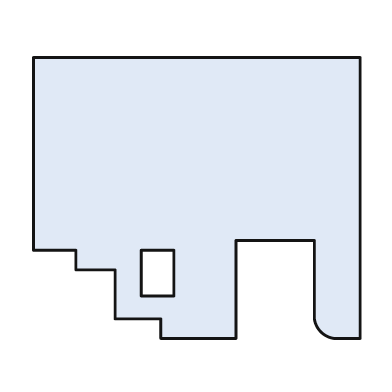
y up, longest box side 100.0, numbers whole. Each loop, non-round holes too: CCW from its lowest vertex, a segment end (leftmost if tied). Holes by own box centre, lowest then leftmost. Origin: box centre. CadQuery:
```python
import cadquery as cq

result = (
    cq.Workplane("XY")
    .moveTo(-11.0, -43.0)
    .lineTo(12.0, -43.0)
    .lineTo(12.0, -13.0)
    .lineTo(36.0, -13.0)
    .lineTo(36.0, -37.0)
    .threePointArc((38.0, -41.0), (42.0, -43.0))
    .lineTo(50.0, -43.0)
    .lineTo(50.0, 43.0)
    .lineTo(-50.0, 43.0)
    .lineTo(-50.0, -16.0)
    .lineTo(-37.0, -16.0)
    .lineTo(-37.0, -22.0)
    .lineTo(-25.0, -22.0)
    .lineTo(-25.0, -37.0)
    .lineTo(-11.0, -37.0)
    .close()
    .moveTo(-17.0, -30.0)
    .lineTo(-7.0, -30.0)
    .lineTo(-7.0, -16.0)
    .lineTo(-17.0, -16.0)
    .close()
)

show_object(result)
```